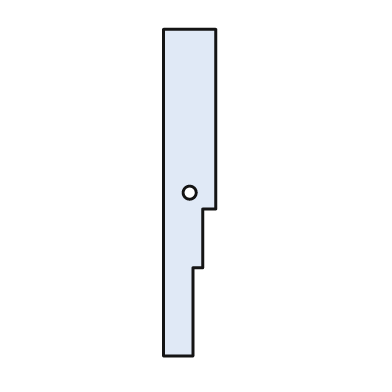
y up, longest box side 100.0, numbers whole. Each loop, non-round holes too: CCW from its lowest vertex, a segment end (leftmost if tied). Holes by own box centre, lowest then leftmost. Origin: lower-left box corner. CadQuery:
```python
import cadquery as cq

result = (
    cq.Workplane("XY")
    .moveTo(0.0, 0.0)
    .lineTo(9.0, 0.0)
    .lineTo(9.0, 27.0)
    .lineTo(12.0, 27.0)
    .lineTo(12.0, 45.0)
    .lineTo(16.0, 45.0)
    .lineTo(16.0, 100.0)
    .lineTo(0.0, 100.0)
    .close()
    .moveTo(8.0, 50.0)
    .circle(2.0)
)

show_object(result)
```